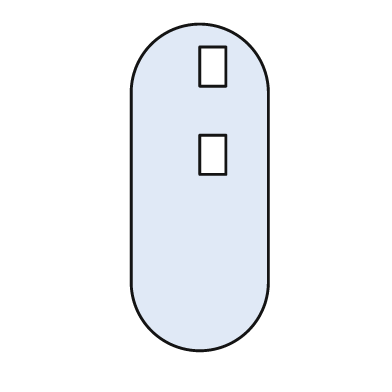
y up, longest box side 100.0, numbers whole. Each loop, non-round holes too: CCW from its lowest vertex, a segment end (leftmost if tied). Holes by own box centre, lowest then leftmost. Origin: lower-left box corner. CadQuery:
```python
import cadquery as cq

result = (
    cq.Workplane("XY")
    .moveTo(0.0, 21.0)
    .threePointArc((21.0, 0.0), (42.0, 21.0))
    .lineTo(42.0, 79.0)
    .threePointArc((21.0, 100.0), (0.0, 79.0))
    .close()
    .moveTo(21.0, 54.0)
    .lineTo(29.0, 54.0)
    .lineTo(29.0, 66.0)
    .lineTo(21.0, 66.0)
    .close()
    .moveTo(21.0, 81.0)
    .lineTo(29.0, 81.0)
    .lineTo(29.0, 93.0)
    .lineTo(21.0, 93.0)
    .close()
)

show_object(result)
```